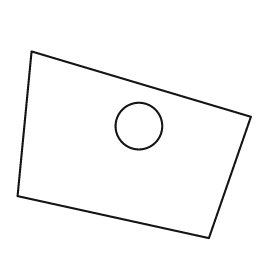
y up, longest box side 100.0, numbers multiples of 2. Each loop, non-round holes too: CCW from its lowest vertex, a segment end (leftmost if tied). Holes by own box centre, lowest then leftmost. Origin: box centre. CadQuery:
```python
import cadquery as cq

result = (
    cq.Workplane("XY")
    .moveTo(32.0, -40.0)
    .lineTo(50.0, 12.0)
    .lineTo(-44.0, 40.0)
    .lineTo(-50.0, -22.0)
    .close()
    .moveTo(2.0, 8.0)
    .circle(10.0)
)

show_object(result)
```